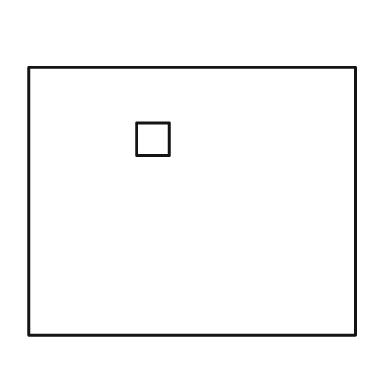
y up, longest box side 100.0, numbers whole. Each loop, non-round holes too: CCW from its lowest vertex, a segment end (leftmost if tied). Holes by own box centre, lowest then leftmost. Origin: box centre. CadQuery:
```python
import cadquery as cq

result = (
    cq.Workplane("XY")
    .moveTo(-50.0, -41.0)
    .lineTo(50.0, -41.0)
    .lineTo(50.0, 41.0)
    .lineTo(-50.0, 41.0)
    .close()
    .moveTo(-17.0, 14.0)
    .lineTo(-7.0, 14.0)
    .lineTo(-7.0, 24.0)
    .lineTo(-17.0, 24.0)
    .close()
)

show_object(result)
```